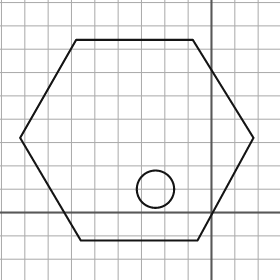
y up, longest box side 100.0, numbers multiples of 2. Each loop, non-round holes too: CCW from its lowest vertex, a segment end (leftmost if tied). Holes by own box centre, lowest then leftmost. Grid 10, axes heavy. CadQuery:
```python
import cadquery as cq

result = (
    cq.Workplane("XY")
    .moveTo(-56.0, -12.0)
    .lineTo(-6.0, -12.0)
    .lineTo(18.0, 32.0)
    .lineTo(-8.0, 74.0)
    .lineTo(-58.0, 74.0)
    .lineTo(-82.0, 32.0)
    .close()
    .moveTo(-24.0, 10.0)
    .circle(8.0)
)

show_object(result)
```